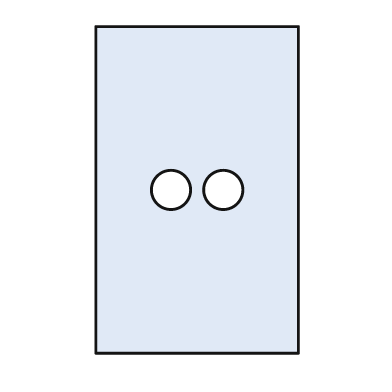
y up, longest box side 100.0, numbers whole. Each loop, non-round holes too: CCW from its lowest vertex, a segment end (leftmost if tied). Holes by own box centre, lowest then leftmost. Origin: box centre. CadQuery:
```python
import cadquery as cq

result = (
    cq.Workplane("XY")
    .moveTo(-31.0, -50.0)
    .lineTo(31.0, -50.0)
    .lineTo(31.0, 50.0)
    .lineTo(-31.0, 50.0)
    .close()
    .moveTo(-8.0, 0.0)
    .circle(6.0)
    .moveTo(8.0, 0.0)
    .circle(6.0)
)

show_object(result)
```